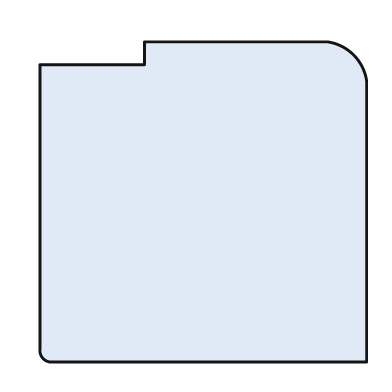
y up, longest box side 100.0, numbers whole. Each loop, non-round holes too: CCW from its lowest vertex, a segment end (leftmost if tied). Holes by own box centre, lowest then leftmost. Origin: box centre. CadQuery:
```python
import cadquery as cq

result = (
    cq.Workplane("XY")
    .moveTo(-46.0, -49.0)
    .lineTo(50.0, -49.0)
    .lineTo(50.0, 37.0)
    .threePointArc((46.0, 45.0), (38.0, 49.0))
    .lineTo(-18.0, 49.0)
    .lineTo(-18.0, 42.0)
    .lineTo(-50.0, 42.0)
    .lineTo(-50.0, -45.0)
    .threePointArc((-49.0, -48.0), (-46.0, -49.0))
    .close()
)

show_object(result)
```